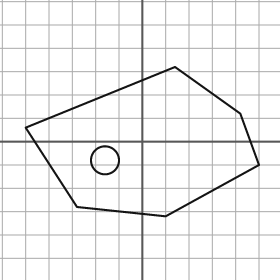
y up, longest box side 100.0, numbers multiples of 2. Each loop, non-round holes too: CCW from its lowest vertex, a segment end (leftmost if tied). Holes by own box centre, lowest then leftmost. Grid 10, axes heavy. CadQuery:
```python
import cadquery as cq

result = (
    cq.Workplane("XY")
    .moveTo(10.0, -32.0)
    .lineTo(50.0, -10.0)
    .lineTo(42.0, 12.0)
    .lineTo(14.0, 32.0)
    .lineTo(-50.0, 6.0)
    .lineTo(-28.0, -28.0)
    .close()
    .moveTo(-16.0, -8.0)
    .circle(6.0)
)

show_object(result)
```